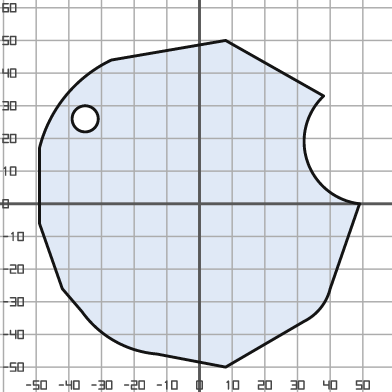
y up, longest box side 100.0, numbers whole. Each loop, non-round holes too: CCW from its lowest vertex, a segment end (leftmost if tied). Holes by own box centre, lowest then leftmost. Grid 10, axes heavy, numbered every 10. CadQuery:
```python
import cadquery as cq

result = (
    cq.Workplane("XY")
    .moveTo(8.0, -50.0)
    .lineTo(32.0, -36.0)
    .threePointArc((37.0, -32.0), (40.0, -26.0))
    .lineTo(49.0, 0.0)
    .threePointArc((33.0, 13.0), (38.0, 33.0))
    .lineTo(8.0, 50.0)
    .lineTo(-27.0, 44.0)
    .threePointArc((-41.0, 33.0), (-49.0, 17.0))
    .lineTo(-49.0, -6.0)
    .lineTo(-42.0, -26.0)
    .lineTo(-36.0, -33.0)
    .threePointArc((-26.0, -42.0), (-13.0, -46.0))
    .close()
    .moveTo(-35.0, 26.0)
    .circle(4.0)
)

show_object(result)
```